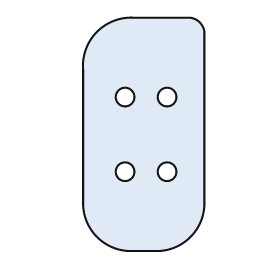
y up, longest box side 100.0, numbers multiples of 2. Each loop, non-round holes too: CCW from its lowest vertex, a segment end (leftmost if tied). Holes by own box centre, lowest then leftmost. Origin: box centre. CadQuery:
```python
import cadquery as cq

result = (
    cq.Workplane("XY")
    .moveTo(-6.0, -50.0)
    .lineTo(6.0, -50.0)
    .threePointArc((20.0, -44.0), (26.0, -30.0))
    .lineTo(26.0, 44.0)
    .threePointArc((24.0, 48.0), (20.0, 50.0))
    .lineTo(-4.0, 50.0)
    .threePointArc((-20.0, 44.0), (-26.0, 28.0))
    .lineTo(-26.0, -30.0)
    .threePointArc((-20.0, -44.0), (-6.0, -50.0))
    .close()
    .moveTo(-8.0, -16.0)
    .circle(4.0)
    .moveTo(10.0, -16.0)
    .circle(4.0)
    .moveTo(-8.0, 16.0)
    .circle(4.0)
    .moveTo(10.0, 16.0)
    .circle(4.0)
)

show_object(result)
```